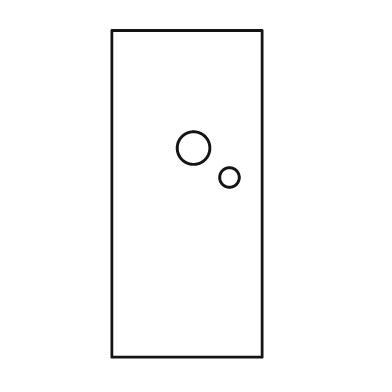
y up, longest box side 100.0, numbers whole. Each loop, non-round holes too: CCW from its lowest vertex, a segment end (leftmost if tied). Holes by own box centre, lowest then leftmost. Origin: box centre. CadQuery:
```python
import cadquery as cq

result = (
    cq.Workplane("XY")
    .moveTo(-23.0, -50.0)
    .lineTo(23.0, -50.0)
    .lineTo(23.0, 50.0)
    .lineTo(-23.0, 50.0)
    .close()
    .moveTo(13.0, 5.0)
    .circle(3.0)
    .moveTo(2.0, 14.0)
    .circle(5.0)
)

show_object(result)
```